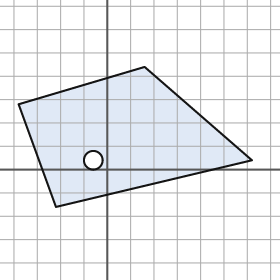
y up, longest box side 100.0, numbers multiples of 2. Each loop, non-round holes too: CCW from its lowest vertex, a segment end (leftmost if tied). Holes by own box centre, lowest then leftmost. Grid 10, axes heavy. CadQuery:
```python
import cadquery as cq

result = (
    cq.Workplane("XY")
    .moveTo(-22.0, -16.0)
    .lineTo(62.0, 4.0)
    .lineTo(16.0, 44.0)
    .lineTo(-38.0, 28.0)
    .close()
    .moveTo(-6.0, 4.0)
    .circle(4.0)
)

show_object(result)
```